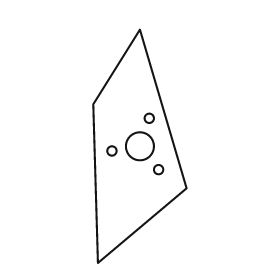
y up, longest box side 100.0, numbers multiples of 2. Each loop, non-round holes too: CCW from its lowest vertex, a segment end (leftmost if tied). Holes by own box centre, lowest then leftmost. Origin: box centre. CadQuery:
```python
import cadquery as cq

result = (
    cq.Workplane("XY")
    .moveTo(-18.0, -50.0)
    .lineTo(20.0, -18.0)
    .lineTo(0.0, 50.0)
    .lineTo(-20.0, 18.0)
    .close()
    .moveTo(8.0, -10.0)
    .circle(2.0)
    .moveTo(-12.0, -2.0)
    .circle(2.0)
    .moveTo(0.0, 0.0)
    .circle(6.0)
    .moveTo(4.0, 12.0)
    .circle(2.0)
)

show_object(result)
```